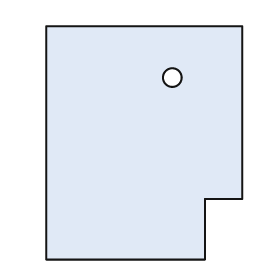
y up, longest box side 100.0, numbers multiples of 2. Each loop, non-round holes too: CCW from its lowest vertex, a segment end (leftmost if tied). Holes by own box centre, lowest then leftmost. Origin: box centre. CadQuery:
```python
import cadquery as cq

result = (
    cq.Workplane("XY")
    .moveTo(-42.0, -50.0)
    .lineTo(26.0, -50.0)
    .lineTo(26.0, -24.0)
    .lineTo(42.0, -24.0)
    .lineTo(42.0, 50.0)
    .lineTo(-42.0, 50.0)
    .close()
    .moveTo(12.0, 28.0)
    .circle(4.0)
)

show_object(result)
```